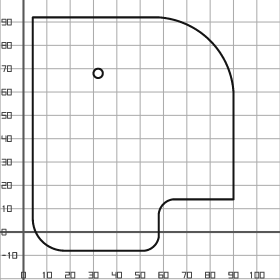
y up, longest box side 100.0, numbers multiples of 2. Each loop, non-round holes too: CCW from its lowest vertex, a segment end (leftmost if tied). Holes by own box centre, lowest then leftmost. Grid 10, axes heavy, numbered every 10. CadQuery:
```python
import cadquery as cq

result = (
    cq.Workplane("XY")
    .moveTo(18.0, -8.0)
    .lineTo(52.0, -8.0)
    .threePointArc((56.0, -6.0), (58.0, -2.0))
    .lineTo(58.0, 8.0)
    .threePointArc((60.0, 12.0), (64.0, 14.0))
    .lineTo(90.0, 14.0)
    .lineTo(90.0, 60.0)
    .threePointArc((80.0, 82.0), (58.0, 92.0))
    .lineTo(4.0, 92.0)
    .lineTo(4.0, 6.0)
    .threePointArc((8.0, -4.0), (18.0, -8.0))
    .close()
    .moveTo(32.0, 68.0)
    .circle(2.0)
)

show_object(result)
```